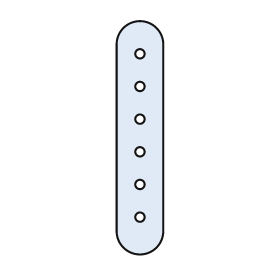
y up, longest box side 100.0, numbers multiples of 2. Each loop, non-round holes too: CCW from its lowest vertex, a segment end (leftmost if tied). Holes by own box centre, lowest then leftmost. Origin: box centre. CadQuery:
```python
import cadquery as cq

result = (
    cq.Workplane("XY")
    .moveTo(-10.0, -40.0)
    .threePointArc((0.0, -50.0), (10.0, -40.0))
    .lineTo(10.0, 40.0)
    .threePointArc((0.0, 50.0), (-10.0, 40.0))
    .close()
    .moveTo(0.0, -34.0)
    .circle(2.0)
    .moveTo(0.0, -20.0)
    .circle(2.0)
    .moveTo(0.0, -6.0)
    .circle(2.0)
    .moveTo(0.0, 8.0)
    .circle(2.0)
    .moveTo(0.0, 22.0)
    .circle(2.0)
    .moveTo(0.0, 36.0)
    .circle(2.0)
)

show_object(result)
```